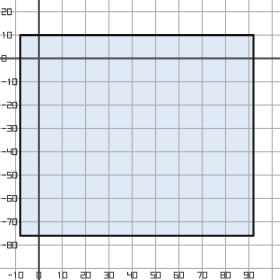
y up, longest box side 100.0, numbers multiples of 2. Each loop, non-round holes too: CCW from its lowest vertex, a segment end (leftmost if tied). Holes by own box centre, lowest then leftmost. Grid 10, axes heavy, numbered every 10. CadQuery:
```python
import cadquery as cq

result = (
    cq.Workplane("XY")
    .moveTo(-8.0, -76.0)
    .lineTo(92.0, -76.0)
    .lineTo(92.0, 10.0)
    .lineTo(-8.0, 10.0)
    .close()
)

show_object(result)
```